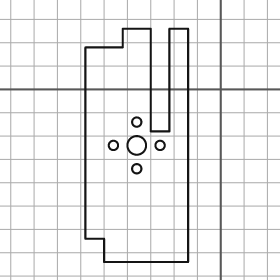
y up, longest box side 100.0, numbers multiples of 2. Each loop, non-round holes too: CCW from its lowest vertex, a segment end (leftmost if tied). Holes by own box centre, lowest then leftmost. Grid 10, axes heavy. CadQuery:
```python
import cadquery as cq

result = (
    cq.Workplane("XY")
    .moveTo(-50.0, -74.0)
    .lineTo(-14.0, -74.0)
    .lineTo(-14.0, 26.0)
    .lineTo(-22.0, 26.0)
    .lineTo(-22.0, -18.0)
    .lineTo(-30.0, -18.0)
    .lineTo(-30.0, 26.0)
    .lineTo(-42.0, 26.0)
    .lineTo(-42.0, 18.0)
    .lineTo(-58.0, 18.0)
    .lineTo(-58.0, -64.0)
    .lineTo(-50.0, -64.0)
    .close()
    .moveTo(-36.0, -34.0)
    .circle(2.0)
    .moveTo(-46.0, -24.0)
    .circle(2.0)
    .moveTo(-36.0, -24.0)
    .circle(4.0)
    .moveTo(-26.0, -24.0)
    .circle(2.0)
    .moveTo(-36.0, -14.0)
    .circle(2.0)
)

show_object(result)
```